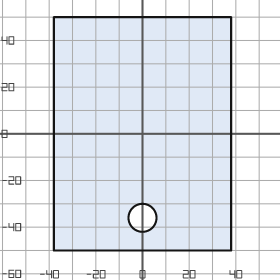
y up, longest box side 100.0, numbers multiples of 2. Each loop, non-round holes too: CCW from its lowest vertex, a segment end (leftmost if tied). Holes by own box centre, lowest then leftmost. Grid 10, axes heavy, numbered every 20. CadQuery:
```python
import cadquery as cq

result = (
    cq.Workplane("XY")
    .moveTo(-38.0, -50.0)
    .lineTo(38.0, -50.0)
    .lineTo(38.0, 50.0)
    .lineTo(-38.0, 50.0)
    .close()
    .moveTo(0.0, -36.0)
    .circle(6.0)
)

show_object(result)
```